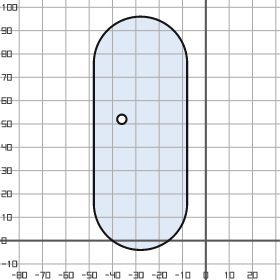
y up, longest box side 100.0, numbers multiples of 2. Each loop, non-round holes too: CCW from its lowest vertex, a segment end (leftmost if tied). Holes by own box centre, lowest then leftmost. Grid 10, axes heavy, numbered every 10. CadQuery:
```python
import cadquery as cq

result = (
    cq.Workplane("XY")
    .moveTo(-48.0, 16.0)
    .threePointArc((-28.0, -4.0), (-8.0, 16.0))
    .lineTo(-8.0, 76.0)
    .threePointArc((-28.0, 96.0), (-48.0, 76.0))
    .close()
    .moveTo(-36.0, 52.0)
    .circle(2.0)
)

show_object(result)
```